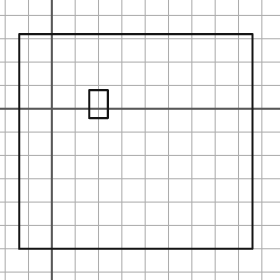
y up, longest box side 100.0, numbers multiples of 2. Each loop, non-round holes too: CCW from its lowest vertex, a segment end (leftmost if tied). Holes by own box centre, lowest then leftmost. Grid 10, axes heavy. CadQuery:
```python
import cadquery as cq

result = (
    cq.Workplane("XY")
    .moveTo(-14.0, -60.0)
    .lineTo(86.0, -60.0)
    .lineTo(86.0, 32.0)
    .lineTo(-14.0, 32.0)
    .close()
    .moveTo(16.0, -4.0)
    .lineTo(24.0, -4.0)
    .lineTo(24.0, 8.0)
    .lineTo(16.0, 8.0)
    .close()
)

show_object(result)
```